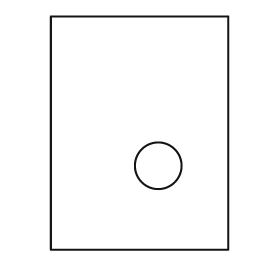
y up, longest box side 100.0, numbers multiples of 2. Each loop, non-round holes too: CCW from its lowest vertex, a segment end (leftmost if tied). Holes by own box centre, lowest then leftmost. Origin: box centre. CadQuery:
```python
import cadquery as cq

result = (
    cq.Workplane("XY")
    .moveTo(-38.0, -50.0)
    .lineTo(38.0, -50.0)
    .lineTo(38.0, 50.0)
    .lineTo(-38.0, 50.0)
    .close()
    .moveTo(8.0, -14.0)
    .circle(10.0)
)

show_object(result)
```